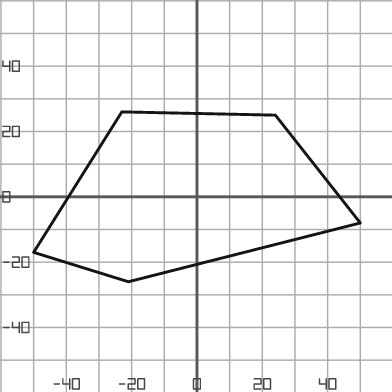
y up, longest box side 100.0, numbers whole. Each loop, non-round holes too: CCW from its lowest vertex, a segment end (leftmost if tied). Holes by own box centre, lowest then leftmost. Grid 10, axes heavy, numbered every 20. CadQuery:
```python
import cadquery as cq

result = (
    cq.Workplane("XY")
    .moveTo(-21.0, -26.0)
    .lineTo(50.0, -8.0)
    .lineTo(24.0, 25.0)
    .lineTo(-23.0, 26.0)
    .lineTo(-50.0, -17.0)
    .close()
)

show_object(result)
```